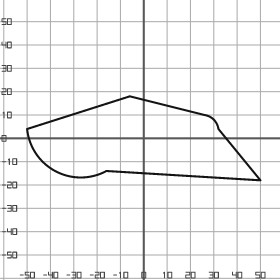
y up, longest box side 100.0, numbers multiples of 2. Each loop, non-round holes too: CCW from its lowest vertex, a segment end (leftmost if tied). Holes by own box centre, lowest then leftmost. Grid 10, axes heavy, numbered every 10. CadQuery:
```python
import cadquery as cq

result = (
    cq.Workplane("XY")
    .moveTo(50.0, -18.0)
    .lineTo(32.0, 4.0)
    .threePointArc((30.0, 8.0), (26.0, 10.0))
    .lineTo(-6.0, 18.0)
    .lineTo(-50.0, 4.0)
    .threePointArc((-38.0, -14.0), (-16.0, -14.0))
    .close()
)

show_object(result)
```